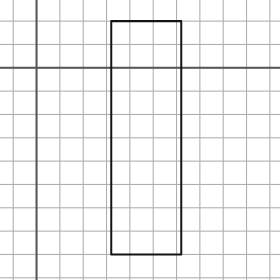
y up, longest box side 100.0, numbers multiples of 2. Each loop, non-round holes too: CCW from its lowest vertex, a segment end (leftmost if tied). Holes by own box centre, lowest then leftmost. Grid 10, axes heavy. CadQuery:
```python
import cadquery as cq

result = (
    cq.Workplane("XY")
    .moveTo(32.0, -80.0)
    .lineTo(62.0, -80.0)
    .lineTo(62.0, 20.0)
    .lineTo(32.0, 20.0)
    .close()
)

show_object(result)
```